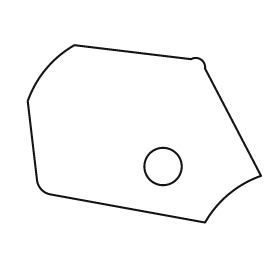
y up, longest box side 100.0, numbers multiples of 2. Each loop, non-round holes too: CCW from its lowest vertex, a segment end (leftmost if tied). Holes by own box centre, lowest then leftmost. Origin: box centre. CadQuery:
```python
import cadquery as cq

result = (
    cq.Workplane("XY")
    .moveTo(26.0, -38.0)
    .threePointArc((36.0, -26.0), (50.0, -18.0))
    .lineTo(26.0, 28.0)
    .threePointArc((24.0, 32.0), (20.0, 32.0))
    .lineTo(-30.0, 38.0)
    .threePointArc((-42.0, 28.0), (-50.0, 14.0))
    .lineTo(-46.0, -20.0)
    .threePointArc((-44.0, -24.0), (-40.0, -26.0))
    .close()
    .moveTo(8.0, -14.0)
    .circle(8.0)
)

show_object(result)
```